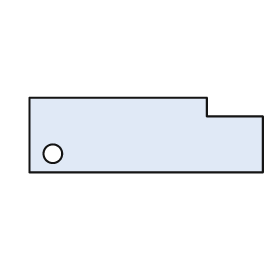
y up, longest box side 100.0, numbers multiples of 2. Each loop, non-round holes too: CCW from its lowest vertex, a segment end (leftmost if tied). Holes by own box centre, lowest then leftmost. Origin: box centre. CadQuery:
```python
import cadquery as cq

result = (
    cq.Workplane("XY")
    .moveTo(-50.0, -16.0)
    .lineTo(50.0, -16.0)
    .lineTo(50.0, 8.0)
    .lineTo(26.0, 8.0)
    .lineTo(26.0, 16.0)
    .lineTo(-50.0, 16.0)
    .close()
    .moveTo(-40.0, -8.0)
    .circle(4.0)
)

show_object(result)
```